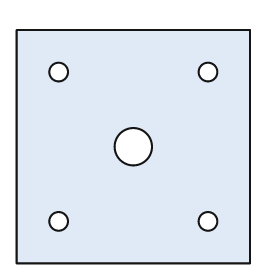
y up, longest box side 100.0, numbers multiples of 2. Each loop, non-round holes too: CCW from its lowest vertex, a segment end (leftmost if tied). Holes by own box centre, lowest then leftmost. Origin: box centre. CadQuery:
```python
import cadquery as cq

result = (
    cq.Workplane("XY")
    .moveTo(-50.0, -50.0)
    .lineTo(50.0, -50.0)
    .lineTo(50.0, 50.0)
    .lineTo(-50.0, 50.0)
    .close()
    .moveTo(-32.0, -32.0)
    .circle(4.0)
    .moveTo(32.0, -32.0)
    .circle(4.0)
    .moveTo(0.0, 0.0)
    .circle(8.0)
    .moveTo(-32.0, 32.0)
    .circle(4.0)
    .moveTo(32.0, 32.0)
    .circle(4.0)
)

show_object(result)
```